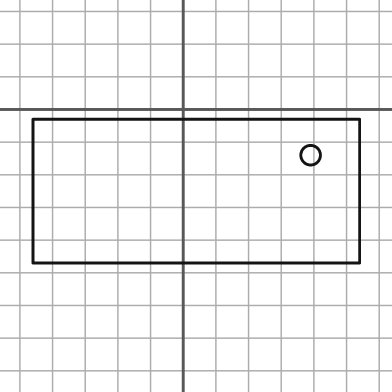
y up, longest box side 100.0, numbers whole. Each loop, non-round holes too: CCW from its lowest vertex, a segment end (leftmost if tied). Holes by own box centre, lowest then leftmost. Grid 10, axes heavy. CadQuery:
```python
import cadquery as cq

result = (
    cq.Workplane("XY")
    .moveTo(-46.0, -47.0)
    .lineTo(54.0, -47.0)
    .lineTo(54.0, -3.0)
    .lineTo(-46.0, -3.0)
    .close()
    .moveTo(39.0, -14.0)
    .circle(3.0)
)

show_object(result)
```